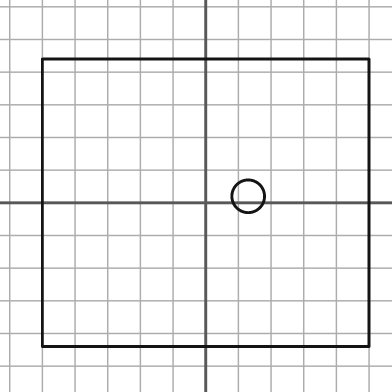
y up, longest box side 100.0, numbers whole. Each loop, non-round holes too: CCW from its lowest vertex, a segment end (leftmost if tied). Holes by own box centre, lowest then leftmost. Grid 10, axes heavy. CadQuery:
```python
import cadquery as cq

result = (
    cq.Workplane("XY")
    .moveTo(-50.0, -44.0)
    .lineTo(50.0, -44.0)
    .lineTo(50.0, 44.0)
    .lineTo(-50.0, 44.0)
    .close()
    .moveTo(13.0, 2.0)
    .circle(5.0)
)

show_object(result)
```